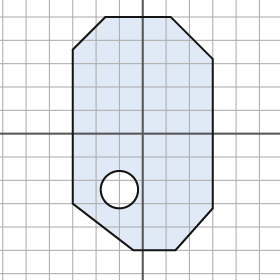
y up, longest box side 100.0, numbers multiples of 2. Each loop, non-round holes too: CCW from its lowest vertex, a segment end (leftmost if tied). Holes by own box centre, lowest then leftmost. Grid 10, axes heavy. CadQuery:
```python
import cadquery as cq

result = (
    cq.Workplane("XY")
    .moveTo(-4.0, -50.0)
    .lineTo(14.0, -50.0)
    .lineTo(30.0, -32.0)
    .lineTo(30.0, 32.0)
    .lineTo(12.0, 50.0)
    .lineTo(-16.0, 50.0)
    .lineTo(-30.0, 36.0)
    .lineTo(-30.0, -30.0)
    .close()
    .moveTo(-10.0, -24.0)
    .circle(8.0)
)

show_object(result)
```